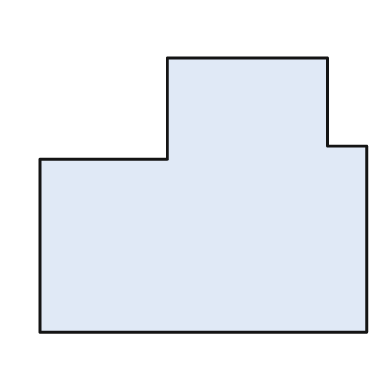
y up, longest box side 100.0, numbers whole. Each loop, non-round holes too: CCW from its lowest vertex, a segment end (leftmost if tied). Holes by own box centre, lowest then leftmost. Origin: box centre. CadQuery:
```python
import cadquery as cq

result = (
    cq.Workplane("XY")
    .moveTo(-50.0, -42.0)
    .lineTo(50.0, -42.0)
    .lineTo(50.0, 15.0)
    .lineTo(38.0, 15.0)
    .lineTo(38.0, 42.0)
    .lineTo(-11.0, 42.0)
    .lineTo(-11.0, 11.0)
    .lineTo(-50.0, 11.0)
    .close()
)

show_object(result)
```